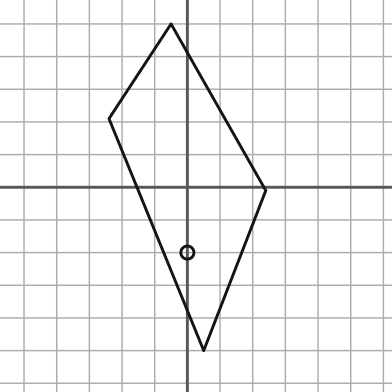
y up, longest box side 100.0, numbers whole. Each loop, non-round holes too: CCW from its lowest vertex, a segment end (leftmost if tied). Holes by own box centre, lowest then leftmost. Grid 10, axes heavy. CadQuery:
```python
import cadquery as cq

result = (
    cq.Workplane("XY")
    .moveTo(5.0, -50.0)
    .lineTo(24.0, -1.0)
    .lineTo(-5.0, 50.0)
    .lineTo(-24.0, 21.0)
    .close()
    .moveTo(0.0, -20.0)
    .circle(2.0)
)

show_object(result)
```